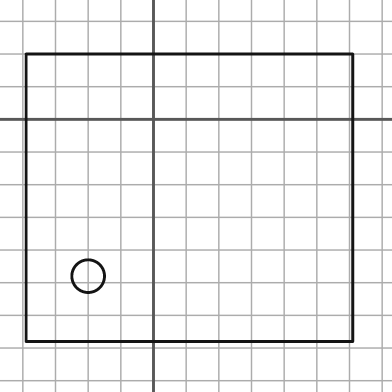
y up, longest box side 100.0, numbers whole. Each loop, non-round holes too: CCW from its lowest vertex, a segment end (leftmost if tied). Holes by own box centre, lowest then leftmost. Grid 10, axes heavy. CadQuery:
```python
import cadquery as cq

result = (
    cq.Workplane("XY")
    .moveTo(-39.0, -68.0)
    .lineTo(61.0, -68.0)
    .lineTo(61.0, 20.0)
    .lineTo(-39.0, 20.0)
    .close()
    .moveTo(-20.0, -48.0)
    .circle(5.0)
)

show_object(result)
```